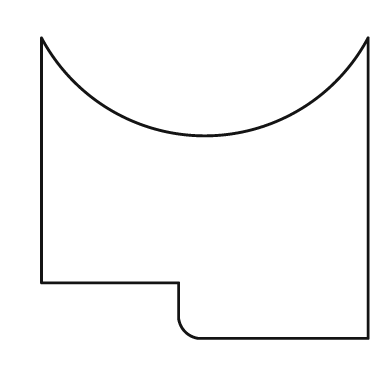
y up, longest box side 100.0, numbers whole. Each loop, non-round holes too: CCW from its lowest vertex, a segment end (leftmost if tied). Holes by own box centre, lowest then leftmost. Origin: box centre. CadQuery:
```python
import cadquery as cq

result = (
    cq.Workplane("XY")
    .moveTo(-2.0, -46.0)
    .lineTo(50.0, -46.0)
    .lineTo(50.0, 46.0)
    .threePointArc((0.0, 16.0), (-50.0, 46.0))
    .lineTo(-50.0, -29.0)
    .lineTo(-8.0, -29.0)
    .lineTo(-8.0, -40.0)
    .threePointArc((-6.0, -44.0), (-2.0, -46.0))
    .close()
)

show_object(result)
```